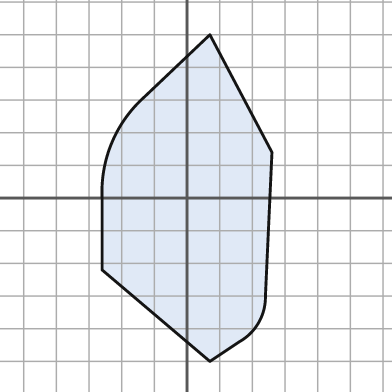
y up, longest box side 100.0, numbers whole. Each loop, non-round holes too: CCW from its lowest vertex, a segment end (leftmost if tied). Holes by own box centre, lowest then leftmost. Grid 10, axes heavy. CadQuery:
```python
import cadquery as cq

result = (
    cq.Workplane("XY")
    .moveTo(7.0, -50.0)
    .lineTo(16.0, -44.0)
    .threePointArc((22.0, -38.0), (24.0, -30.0))
    .lineTo(26.0, 14.0)
    .lineTo(7.0, 50.0)
    .lineTo(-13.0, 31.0)
    .threePointArc((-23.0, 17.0), (-26.0, 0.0))
    .lineTo(-26.0, -22.0)
    .close()
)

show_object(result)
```